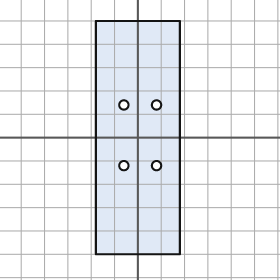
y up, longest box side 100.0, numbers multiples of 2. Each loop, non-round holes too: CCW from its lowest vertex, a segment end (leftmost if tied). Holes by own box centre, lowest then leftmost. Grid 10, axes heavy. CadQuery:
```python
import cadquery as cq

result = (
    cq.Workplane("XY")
    .moveTo(-18.0, -50.0)
    .lineTo(18.0, -50.0)
    .lineTo(18.0, 50.0)
    .lineTo(-18.0, 50.0)
    .close()
    .moveTo(-6.0, -12.0)
    .circle(2.0)
    .moveTo(8.0, -12.0)
    .circle(2.0)
    .moveTo(-6.0, 14.0)
    .circle(2.0)
    .moveTo(8.0, 14.0)
    .circle(2.0)
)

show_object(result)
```